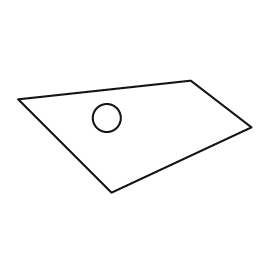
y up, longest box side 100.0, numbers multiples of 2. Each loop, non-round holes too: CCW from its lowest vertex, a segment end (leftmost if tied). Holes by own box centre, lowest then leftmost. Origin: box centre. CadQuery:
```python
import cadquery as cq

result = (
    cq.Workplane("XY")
    .moveTo(-10.0, -24.0)
    .lineTo(50.0, 4.0)
    .lineTo(24.0, 24.0)
    .lineTo(-50.0, 16.0)
    .close()
    .moveTo(-12.0, 8.0)
    .circle(6.0)
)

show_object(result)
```